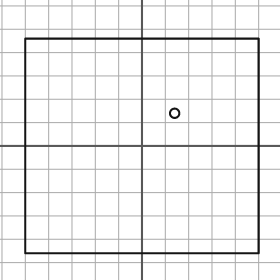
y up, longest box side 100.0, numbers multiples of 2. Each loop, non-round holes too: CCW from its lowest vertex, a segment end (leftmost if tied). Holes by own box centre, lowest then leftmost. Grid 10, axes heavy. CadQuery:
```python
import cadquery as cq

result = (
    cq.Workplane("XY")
    .moveTo(-50.0, -46.0)
    .lineTo(50.0, -46.0)
    .lineTo(50.0, 46.0)
    .lineTo(-50.0, 46.0)
    .close()
    .moveTo(14.0, 14.0)
    .circle(2.0)
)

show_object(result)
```